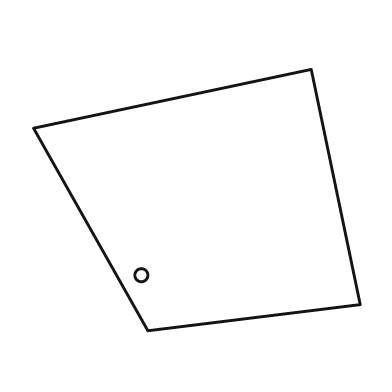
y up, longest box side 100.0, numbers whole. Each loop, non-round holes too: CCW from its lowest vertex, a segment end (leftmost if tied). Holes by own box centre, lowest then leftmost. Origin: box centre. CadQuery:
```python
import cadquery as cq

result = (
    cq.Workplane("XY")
    .moveTo(-15.0, -40.0)
    .lineTo(50.0, -32.0)
    .lineTo(35.0, 40.0)
    .lineTo(-50.0, 22.0)
    .close()
    .moveTo(-17.0, -23.0)
    .circle(2.0)
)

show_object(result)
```